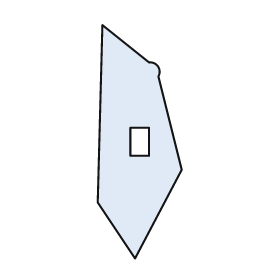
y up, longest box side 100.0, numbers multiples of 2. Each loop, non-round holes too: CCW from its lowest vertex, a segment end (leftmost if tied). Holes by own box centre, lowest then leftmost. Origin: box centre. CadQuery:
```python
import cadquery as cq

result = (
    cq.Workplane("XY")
    .moveTo(-2.0, -50.0)
    .lineTo(18.0, -12.0)
    .lineTo(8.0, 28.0)
    .threePointArc((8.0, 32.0), (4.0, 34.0))
    .lineTo(-16.0, 50.0)
    .lineTo(-18.0, -26.0)
    .close()
    .moveTo(-4.0, -6.0)
    .lineTo(4.0, -6.0)
    .lineTo(4.0, 6.0)
    .lineTo(-4.0, 6.0)
    .close()
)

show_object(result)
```